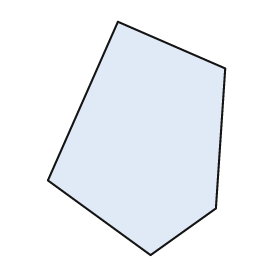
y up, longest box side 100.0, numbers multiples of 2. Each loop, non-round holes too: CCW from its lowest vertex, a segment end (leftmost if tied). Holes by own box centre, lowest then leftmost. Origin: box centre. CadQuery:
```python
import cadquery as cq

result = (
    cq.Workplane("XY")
    .moveTo(6.0, -50.0)
    .lineTo(34.0, -30.0)
    .lineTo(38.0, 30.0)
    .lineTo(-8.0, 50.0)
    .lineTo(-38.0, -18.0)
    .close()
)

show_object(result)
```